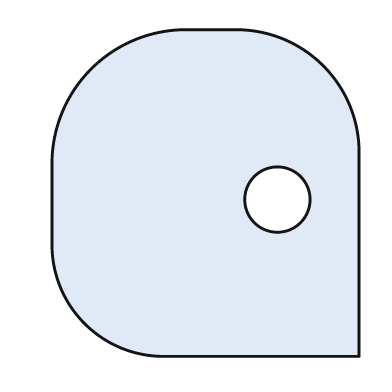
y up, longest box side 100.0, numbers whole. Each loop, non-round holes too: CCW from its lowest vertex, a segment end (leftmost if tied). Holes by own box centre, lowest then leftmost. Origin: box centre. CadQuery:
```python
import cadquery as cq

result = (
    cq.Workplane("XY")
    .moveTo(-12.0, -50.0)
    .lineTo(47.0, -50.0)
    .lineTo(47.0, 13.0)
    .threePointArc((36.0, 39.0), (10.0, 50.0))
    .lineTo(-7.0, 50.0)
    .threePointArc((-35.0, 38.0), (-47.0, 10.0))
    .lineTo(-47.0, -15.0)
    .threePointArc((-37.0, -40.0), (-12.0, -50.0))
    .close()
    .moveTo(22.0, -2.0)
    .circle(10.0)
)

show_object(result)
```